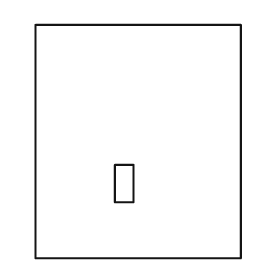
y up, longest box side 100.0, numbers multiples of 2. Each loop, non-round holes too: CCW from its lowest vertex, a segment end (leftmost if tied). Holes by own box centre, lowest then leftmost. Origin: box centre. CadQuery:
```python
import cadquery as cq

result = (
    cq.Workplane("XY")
    .moveTo(-44.0, -50.0)
    .lineTo(44.0, -50.0)
    .lineTo(44.0, 50.0)
    .lineTo(-44.0, 50.0)
    .close()
    .moveTo(-10.0, -26.0)
    .lineTo(-2.0, -26.0)
    .lineTo(-2.0, -10.0)
    .lineTo(-10.0, -10.0)
    .close()
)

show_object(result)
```